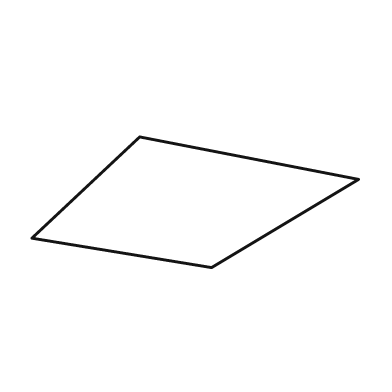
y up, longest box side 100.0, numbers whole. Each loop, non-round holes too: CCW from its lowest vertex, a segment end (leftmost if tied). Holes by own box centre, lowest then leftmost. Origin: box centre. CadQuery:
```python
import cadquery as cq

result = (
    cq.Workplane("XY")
    .moveTo(5.0, -20.0)
    .lineTo(50.0, 7.0)
    .lineTo(-17.0, 20.0)
    .lineTo(-50.0, -11.0)
    .close()
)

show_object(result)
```